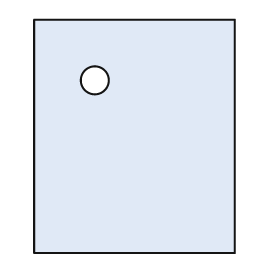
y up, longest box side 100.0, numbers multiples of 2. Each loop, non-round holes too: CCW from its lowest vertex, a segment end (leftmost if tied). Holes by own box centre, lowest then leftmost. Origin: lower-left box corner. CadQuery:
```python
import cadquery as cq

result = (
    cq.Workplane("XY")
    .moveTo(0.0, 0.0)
    .lineTo(86.0, 0.0)
    .lineTo(86.0, 100.0)
    .lineTo(0.0, 100.0)
    .close()
    .moveTo(26.0, 74.0)
    .circle(6.0)
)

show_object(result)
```